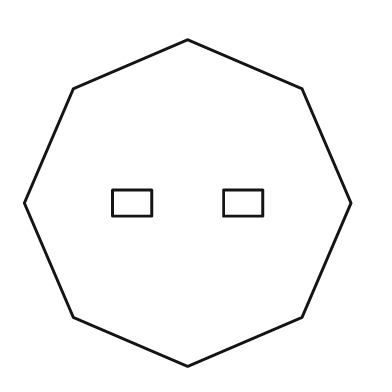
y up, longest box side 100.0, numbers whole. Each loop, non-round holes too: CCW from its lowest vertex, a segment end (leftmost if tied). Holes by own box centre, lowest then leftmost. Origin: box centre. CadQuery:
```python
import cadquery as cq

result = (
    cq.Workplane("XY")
    .moveTo(0.0, -50.0)
    .lineTo(35.0, -35.0)
    .lineTo(50.0, 0.0)
    .lineTo(35.0, 35.0)
    .lineTo(0.0, 50.0)
    .lineTo(-35.0, 35.0)
    .lineTo(-50.0, 0.0)
    .lineTo(-35.0, -35.0)
    .close()
    .moveTo(-23.0, -4.0)
    .lineTo(-11.0, -4.0)
    .lineTo(-11.0, 4.0)
    .lineTo(-23.0, 4.0)
    .close()
    .moveTo(11.0, -4.0)
    .lineTo(23.0, -4.0)
    .lineTo(23.0, 4.0)
    .lineTo(11.0, 4.0)
    .close()
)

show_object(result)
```